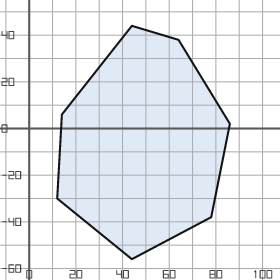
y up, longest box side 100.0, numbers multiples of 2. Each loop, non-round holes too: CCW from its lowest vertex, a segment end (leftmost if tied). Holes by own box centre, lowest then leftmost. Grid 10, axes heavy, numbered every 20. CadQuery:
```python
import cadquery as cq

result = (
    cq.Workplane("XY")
    .moveTo(44.0, -56.0)
    .lineTo(78.0, -38.0)
    .lineTo(86.0, 2.0)
    .lineTo(64.0, 38.0)
    .lineTo(44.0, 44.0)
    .lineTo(14.0, 6.0)
    .lineTo(12.0, -30.0)
    .close()
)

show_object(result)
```